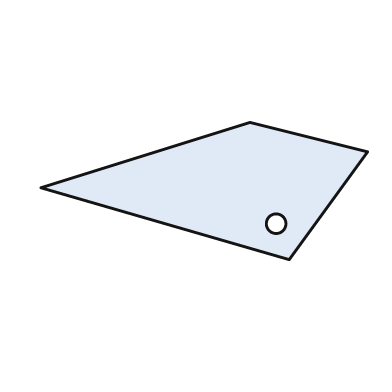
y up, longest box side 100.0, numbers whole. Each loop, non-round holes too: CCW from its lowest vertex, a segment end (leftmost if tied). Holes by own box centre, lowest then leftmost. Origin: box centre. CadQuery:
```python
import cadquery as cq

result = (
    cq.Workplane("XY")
    .moveTo(26.0, -21.0)
    .lineTo(50.0, 12.0)
    .lineTo(14.0, 21.0)
    .lineTo(-50.0, 1.0)
    .close()
    .moveTo(22.0, -10.0)
    .circle(3.0)
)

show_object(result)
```